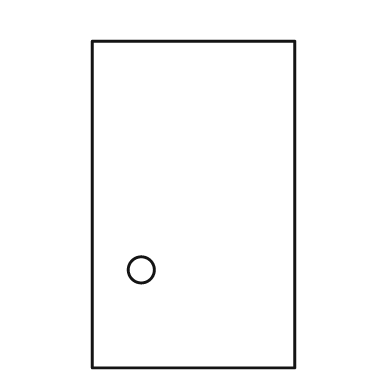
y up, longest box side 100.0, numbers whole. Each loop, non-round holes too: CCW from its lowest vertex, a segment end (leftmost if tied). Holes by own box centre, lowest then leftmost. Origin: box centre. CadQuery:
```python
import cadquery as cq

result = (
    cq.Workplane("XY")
    .moveTo(-31.0, -50.0)
    .lineTo(31.0, -50.0)
    .lineTo(31.0, 50.0)
    .lineTo(-31.0, 50.0)
    .close()
    .moveTo(-16.0, -20.0)
    .circle(4.0)
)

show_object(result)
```